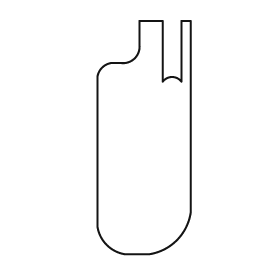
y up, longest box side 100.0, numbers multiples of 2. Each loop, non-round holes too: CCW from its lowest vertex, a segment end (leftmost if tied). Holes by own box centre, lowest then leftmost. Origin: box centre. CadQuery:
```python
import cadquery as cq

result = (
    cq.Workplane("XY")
    .moveTo(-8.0, -50.0)
    .lineTo(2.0, -50.0)
    .threePointArc((14.0, -44.0), (20.0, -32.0))
    .lineTo(20.0, 50.0)
    .lineTo(16.0, 50.0)
    .lineTo(16.0, 24.0)
    .threePointArc((12.0, 26.0), (8.0, 24.0))
    .lineTo(8.0, 50.0)
    .lineTo(-2.0, 50.0)
    .lineTo(-2.0, 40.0)
    .threePointArc((-4.0, 34.0), (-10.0, 32.0))
    .lineTo(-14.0, 32.0)
    .threePointArc((-18.0, 30.0), (-20.0, 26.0))
    .lineTo(-20.0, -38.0)
    .threePointArc((-16.0, -46.0), (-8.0, -50.0))
    .close()
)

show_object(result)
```